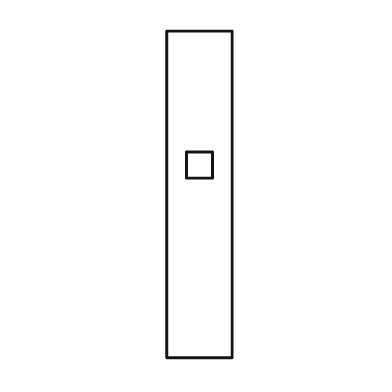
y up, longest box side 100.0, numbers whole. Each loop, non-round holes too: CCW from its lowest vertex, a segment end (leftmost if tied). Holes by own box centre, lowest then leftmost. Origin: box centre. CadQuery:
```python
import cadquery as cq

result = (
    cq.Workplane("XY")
    .moveTo(-10.0, -50.0)
    .lineTo(10.0, -50.0)
    .lineTo(10.0, 50.0)
    .lineTo(-10.0, 50.0)
    .close()
    .moveTo(-4.0, 5.0)
    .lineTo(4.0, 5.0)
    .lineTo(4.0, 13.0)
    .lineTo(-4.0, 13.0)
    .close()
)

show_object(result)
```